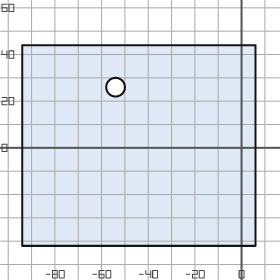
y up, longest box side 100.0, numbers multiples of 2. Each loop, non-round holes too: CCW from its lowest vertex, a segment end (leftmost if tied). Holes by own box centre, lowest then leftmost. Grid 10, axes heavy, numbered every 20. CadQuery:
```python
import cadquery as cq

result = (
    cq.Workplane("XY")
    .moveTo(-94.0, -42.0)
    .lineTo(6.0, -42.0)
    .lineTo(6.0, 44.0)
    .lineTo(-94.0, 44.0)
    .close()
    .moveTo(-54.0, 26.0)
    .circle(4.0)
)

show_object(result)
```